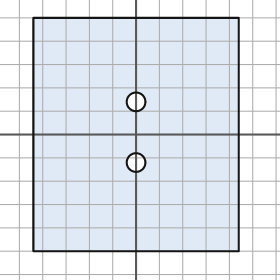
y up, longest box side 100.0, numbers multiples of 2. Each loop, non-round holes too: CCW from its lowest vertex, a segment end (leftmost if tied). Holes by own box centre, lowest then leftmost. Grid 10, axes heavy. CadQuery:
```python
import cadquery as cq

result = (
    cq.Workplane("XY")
    .moveTo(-44.0, -50.0)
    .lineTo(44.0, -50.0)
    .lineTo(44.0, 50.0)
    .lineTo(-44.0, 50.0)
    .close()
    .moveTo(0.0, -12.0)
    .circle(4.0)
    .moveTo(0.0, 14.0)
    .circle(4.0)
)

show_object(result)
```